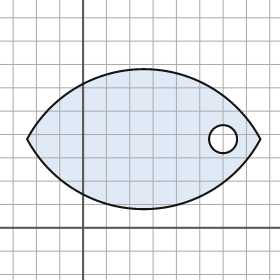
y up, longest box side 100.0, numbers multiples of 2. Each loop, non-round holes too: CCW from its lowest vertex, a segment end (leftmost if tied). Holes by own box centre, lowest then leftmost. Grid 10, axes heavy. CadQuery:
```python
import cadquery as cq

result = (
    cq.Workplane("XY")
    .moveTo(-24.0, 38.0)
    .threePointArc((26.0, 8.0), (76.0, 38.0))
    .threePointArc((26.0, 68.0), (-24.0, 38.0))
    .close()
    .moveTo(60.0, 38.0)
    .circle(6.0)
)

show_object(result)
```